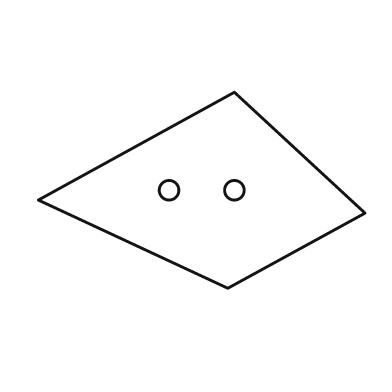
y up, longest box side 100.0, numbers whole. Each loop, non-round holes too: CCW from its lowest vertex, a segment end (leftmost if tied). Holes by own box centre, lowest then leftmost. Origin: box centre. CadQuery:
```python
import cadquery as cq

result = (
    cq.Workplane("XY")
    .moveTo(8.0, -30.0)
    .lineTo(50.0, -7.0)
    .lineTo(10.0, 30.0)
    .lineTo(-50.0, -3.0)
    .close()
    .moveTo(-10.0, 0.0)
    .circle(3.0)
    .moveTo(10.0, 0.0)
    .circle(3.0)
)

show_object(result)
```